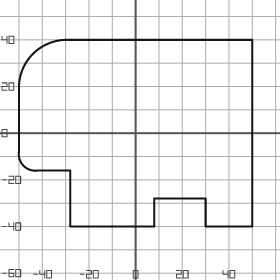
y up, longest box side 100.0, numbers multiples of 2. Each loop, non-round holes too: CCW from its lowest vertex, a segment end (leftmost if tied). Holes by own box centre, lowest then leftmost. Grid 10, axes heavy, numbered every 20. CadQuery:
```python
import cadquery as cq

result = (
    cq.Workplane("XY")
    .moveTo(-28.0, -40.0)
    .lineTo(8.0, -40.0)
    .lineTo(8.0, -28.0)
    .lineTo(30.0, -28.0)
    .lineTo(30.0, -40.0)
    .lineTo(50.0, -40.0)
    .lineTo(50.0, 40.0)
    .lineTo(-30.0, 40.0)
    .threePointArc((-44.0, 34.0), (-50.0, 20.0))
    .lineTo(-50.0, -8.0)
    .threePointArc((-48.0, -14.0), (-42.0, -16.0))
    .lineTo(-28.0, -16.0)
    .close()
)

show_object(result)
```